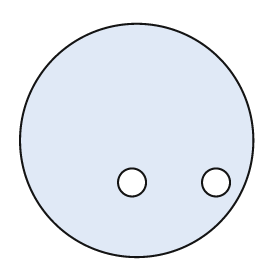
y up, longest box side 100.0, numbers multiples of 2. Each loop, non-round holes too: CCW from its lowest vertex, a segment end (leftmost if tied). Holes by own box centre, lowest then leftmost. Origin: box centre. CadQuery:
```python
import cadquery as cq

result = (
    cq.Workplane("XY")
    .moveTo(0.0, 0.0)
    .circle(50.0)
    .moveTo(-2.0, -18.0)
    .circle(6.0)
    .moveTo(34.0, -18.0)
    .circle(6.0)
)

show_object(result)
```